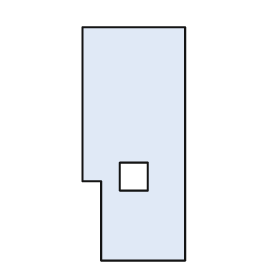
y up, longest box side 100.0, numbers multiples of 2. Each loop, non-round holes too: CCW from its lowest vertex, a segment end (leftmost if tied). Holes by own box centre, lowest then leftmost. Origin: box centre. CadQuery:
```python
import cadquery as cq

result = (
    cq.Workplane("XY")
    .moveTo(-14.0, -50.0)
    .lineTo(22.0, -50.0)
    .lineTo(22.0, 50.0)
    .lineTo(-22.0, 50.0)
    .lineTo(-22.0, -16.0)
    .lineTo(-14.0, -16.0)
    .close()
    .moveTo(-6.0, -20.0)
    .lineTo(6.0, -20.0)
    .lineTo(6.0, -8.0)
    .lineTo(-6.0, -8.0)
    .close()
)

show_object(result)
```